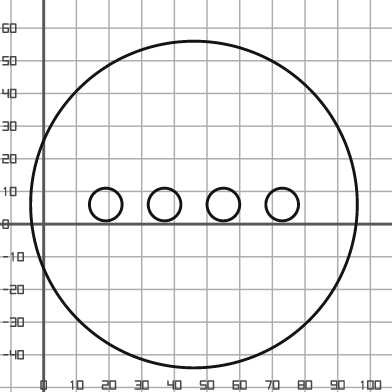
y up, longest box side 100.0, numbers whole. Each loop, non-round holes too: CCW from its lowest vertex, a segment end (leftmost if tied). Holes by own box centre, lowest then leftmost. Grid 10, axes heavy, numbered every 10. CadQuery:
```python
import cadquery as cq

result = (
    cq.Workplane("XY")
    .moveTo(46.0, 6.0)
    .circle(50.0)
    .moveTo(19.0, 6.0)
    .circle(5.0)
    .moveTo(37.0, 6.0)
    .circle(5.0)
    .moveTo(55.0, 6.0)
    .circle(5.0)
    .moveTo(73.0, 6.0)
    .circle(5.0)
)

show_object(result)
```